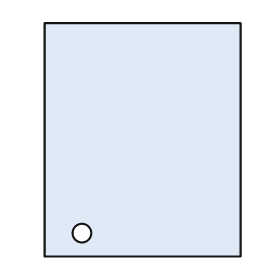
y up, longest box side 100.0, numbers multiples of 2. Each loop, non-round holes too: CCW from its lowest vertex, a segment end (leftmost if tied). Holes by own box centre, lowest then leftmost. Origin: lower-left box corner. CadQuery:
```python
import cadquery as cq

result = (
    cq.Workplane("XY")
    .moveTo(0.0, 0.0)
    .lineTo(84.0, 0.0)
    .lineTo(84.0, 100.0)
    .lineTo(0.0, 100.0)
    .close()
    .moveTo(16.0, 10.0)
    .circle(4.0)
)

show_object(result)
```